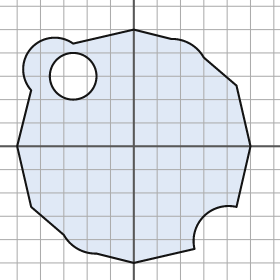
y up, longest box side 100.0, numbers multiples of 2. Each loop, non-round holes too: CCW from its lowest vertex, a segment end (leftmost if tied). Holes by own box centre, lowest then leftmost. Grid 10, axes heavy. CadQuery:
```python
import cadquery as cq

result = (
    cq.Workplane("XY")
    .moveTo(0.0, -50.0)
    .lineTo(26.0, -44.0)
    .threePointArc((30.0, -30.0), (44.0, -26.0))
    .lineTo(50.0, 0.0)
    .lineTo(44.0, 26.0)
    .lineTo(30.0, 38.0)
    .threePointArc((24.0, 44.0), (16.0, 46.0))
    .lineTo(0.0, 50.0)
    .lineTo(-26.0, 44.0)
    .threePointArc((-44.0, 42.0), (-44.0, 24.0))
    .lineTo(-50.0, 0.0)
    .lineTo(-44.0, -26.0)
    .lineTo(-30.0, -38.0)
    .threePointArc((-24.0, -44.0), (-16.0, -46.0))
    .close()
    .moveTo(-26.0, 30.0)
    .circle(10.0)
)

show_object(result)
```